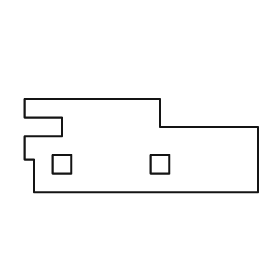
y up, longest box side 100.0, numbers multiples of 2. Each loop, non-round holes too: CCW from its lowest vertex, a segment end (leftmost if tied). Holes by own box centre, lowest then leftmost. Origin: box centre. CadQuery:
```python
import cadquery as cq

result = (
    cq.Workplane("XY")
    .moveTo(-46.0, -20.0)
    .lineTo(50.0, -20.0)
    .lineTo(50.0, 8.0)
    .lineTo(8.0, 8.0)
    .lineTo(8.0, 20.0)
    .lineTo(-50.0, 20.0)
    .lineTo(-50.0, 12.0)
    .lineTo(-34.0, 12.0)
    .lineTo(-34.0, 4.0)
    .lineTo(-50.0, 4.0)
    .lineTo(-50.0, -6.0)
    .lineTo(-46.0, -6.0)
    .close()
    .moveTo(-38.0, -12.0)
    .lineTo(-30.0, -12.0)
    .lineTo(-30.0, -4.0)
    .lineTo(-38.0, -4.0)
    .close()
    .moveTo(4.0, -12.0)
    .lineTo(12.0, -12.0)
    .lineTo(12.0, -4.0)
    .lineTo(4.0, -4.0)
    .close()
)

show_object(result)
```